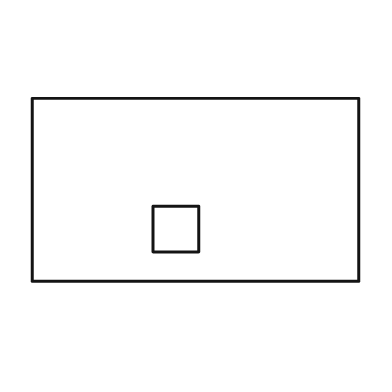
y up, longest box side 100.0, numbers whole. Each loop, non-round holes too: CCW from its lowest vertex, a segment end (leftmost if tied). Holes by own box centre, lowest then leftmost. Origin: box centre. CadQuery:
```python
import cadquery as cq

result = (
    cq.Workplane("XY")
    .moveTo(-50.0, -28.0)
    .lineTo(50.0, -28.0)
    .lineTo(50.0, 28.0)
    .lineTo(-50.0, 28.0)
    .close()
    .moveTo(-13.0, -19.0)
    .lineTo(1.0, -19.0)
    .lineTo(1.0, -5.0)
    .lineTo(-13.0, -5.0)
    .close()
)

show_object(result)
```